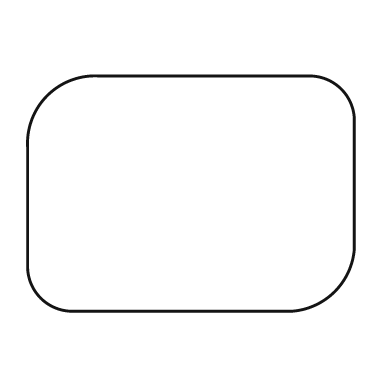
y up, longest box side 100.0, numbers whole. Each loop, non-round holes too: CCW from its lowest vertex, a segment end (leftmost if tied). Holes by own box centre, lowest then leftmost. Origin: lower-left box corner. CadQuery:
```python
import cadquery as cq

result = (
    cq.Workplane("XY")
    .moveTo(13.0, 0.0)
    .lineTo(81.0, 0.0)
    .threePointArc((94.0, 6.0), (100.0, 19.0))
    .lineTo(100.0, 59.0)
    .threePointArc((96.0, 68.0), (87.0, 72.0))
    .lineTo(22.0, 72.0)
    .threePointArc((6.0, 66.0), (0.0, 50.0))
    .lineTo(0.0, 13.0)
    .threePointArc((4.0, 4.0), (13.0, 0.0))
    .close()
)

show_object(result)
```